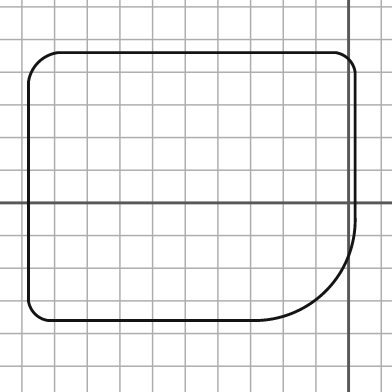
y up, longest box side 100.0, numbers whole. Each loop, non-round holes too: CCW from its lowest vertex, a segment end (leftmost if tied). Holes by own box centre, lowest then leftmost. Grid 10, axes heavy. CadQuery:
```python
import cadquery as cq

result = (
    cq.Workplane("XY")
    .moveTo(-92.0, -36.0)
    .lineTo(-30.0, -36.0)
    .threePointArc((-7.0, -27.0), (2.0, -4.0))
    .lineTo(2.0, 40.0)
    .threePointArc((0.0, 44.0), (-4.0, 46.0))
    .lineTo(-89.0, 46.0)
    .threePointArc((-95.0, 43.0), (-98.0, 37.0))
    .lineTo(-98.0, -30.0)
    .threePointArc((-96.0, -34.0), (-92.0, -36.0))
    .close()
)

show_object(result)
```